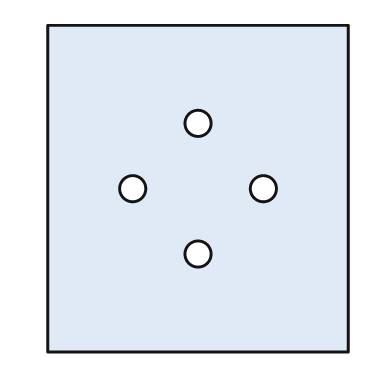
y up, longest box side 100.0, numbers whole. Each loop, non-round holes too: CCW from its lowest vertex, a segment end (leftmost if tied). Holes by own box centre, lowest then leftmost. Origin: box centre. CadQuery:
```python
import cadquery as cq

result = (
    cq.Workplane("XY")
    .moveTo(-46.0, -50.0)
    .lineTo(46.0, -50.0)
    .lineTo(46.0, 50.0)
    .lineTo(-46.0, 50.0)
    .close()
    .moveTo(0.0, -20.0)
    .circle(4.0)
    .moveTo(-20.0, 0.0)
    .circle(4.0)
    .moveTo(20.0, 0.0)
    .circle(4.0)
    .moveTo(0.0, 20.0)
    .circle(4.0)
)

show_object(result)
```